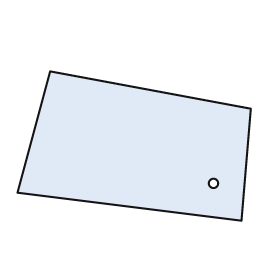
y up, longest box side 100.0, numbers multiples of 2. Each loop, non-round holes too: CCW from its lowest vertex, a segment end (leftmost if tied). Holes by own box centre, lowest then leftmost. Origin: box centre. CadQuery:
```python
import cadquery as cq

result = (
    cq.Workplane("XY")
    .moveTo(46.0, -32.0)
    .lineTo(50.0, 16.0)
    .lineTo(-36.0, 32.0)
    .lineTo(-50.0, -20.0)
    .close()
    .moveTo(34.0, -16.0)
    .circle(2.0)
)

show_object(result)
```